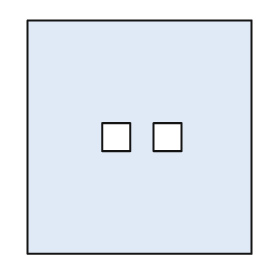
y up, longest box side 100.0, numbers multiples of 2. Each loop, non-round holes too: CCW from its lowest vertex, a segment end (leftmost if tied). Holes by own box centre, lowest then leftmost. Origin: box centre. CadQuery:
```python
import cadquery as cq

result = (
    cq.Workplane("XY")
    .moveTo(-48.0, -50.0)
    .lineTo(48.0, -50.0)
    .lineTo(48.0, 50.0)
    .lineTo(-48.0, 50.0)
    .close()
    .moveTo(-16.0, -6.0)
    .lineTo(-4.0, -6.0)
    .lineTo(-4.0, 6.0)
    .lineTo(-16.0, 6.0)
    .close()
    .moveTo(6.0, -6.0)
    .lineTo(18.0, -6.0)
    .lineTo(18.0, 6.0)
    .lineTo(6.0, 6.0)
    .close()
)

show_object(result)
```